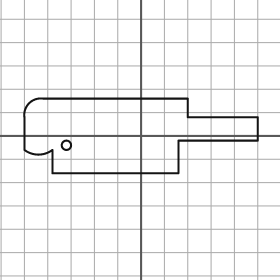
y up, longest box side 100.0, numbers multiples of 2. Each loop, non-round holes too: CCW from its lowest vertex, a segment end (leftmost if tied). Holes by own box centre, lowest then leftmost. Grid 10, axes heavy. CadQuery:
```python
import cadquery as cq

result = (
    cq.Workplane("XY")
    .moveTo(-38.0, -16.0)
    .lineTo(16.0, -16.0)
    .lineTo(16.0, -2.0)
    .lineTo(50.0, -2.0)
    .lineTo(50.0, 8.0)
    .lineTo(20.0, 8.0)
    .lineTo(20.0, 16.0)
    .lineTo(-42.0, 16.0)
    .threePointArc((-48.0, 14.0), (-50.0, 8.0))
    .lineTo(-50.0, -6.0)
    .threePointArc((-44.0, -8.0), (-38.0, -6.0))
    .close()
    .moveTo(-32.0, -4.0)
    .circle(2.0)
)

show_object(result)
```